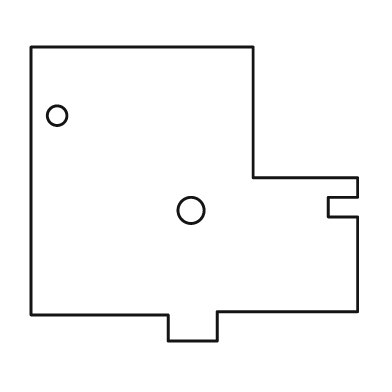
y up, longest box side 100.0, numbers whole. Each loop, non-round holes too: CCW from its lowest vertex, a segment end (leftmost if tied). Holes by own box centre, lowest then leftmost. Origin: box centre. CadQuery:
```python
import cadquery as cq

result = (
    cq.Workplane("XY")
    .moveTo(-8.0, -45.0)
    .lineTo(7.0, -45.0)
    .lineTo(7.0, -36.0)
    .lineTo(50.0, -36.0)
    .lineTo(50.0, -7.0)
    .lineTo(41.0, -7.0)
    .lineTo(41.0, -1.0)
    .lineTo(50.0, -1.0)
    .lineTo(50.0, 5.0)
    .lineTo(18.0, 5.0)
    .lineTo(18.0, 45.0)
    .lineTo(-50.0, 45.0)
    .lineTo(-50.0, -37.0)
    .lineTo(-8.0, -37.0)
    .close()
    .moveTo(-1.0, -5.0)
    .circle(4.0)
    .moveTo(-42.0, 24.0)
    .circle(3.0)
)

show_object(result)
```